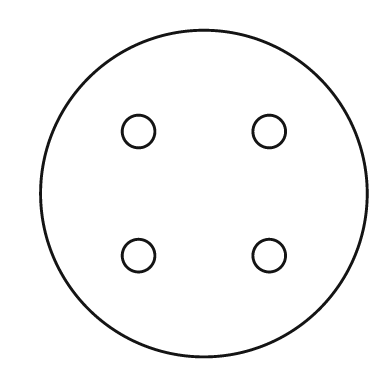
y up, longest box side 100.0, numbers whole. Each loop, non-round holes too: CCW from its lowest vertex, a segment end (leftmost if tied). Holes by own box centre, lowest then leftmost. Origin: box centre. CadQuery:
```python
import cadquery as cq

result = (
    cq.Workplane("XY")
    .moveTo(0.0, 0.0)
    .circle(50.0)
    .moveTo(-20.0, -19.0)
    .circle(5.0)
    .moveTo(20.0, -19.0)
    .circle(5.0)
    .moveTo(-20.0, 19.0)
    .circle(5.0)
    .moveTo(20.0, 19.0)
    .circle(5.0)
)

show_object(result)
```